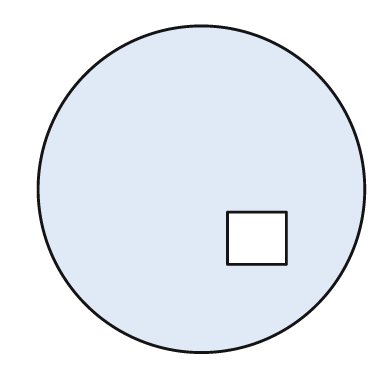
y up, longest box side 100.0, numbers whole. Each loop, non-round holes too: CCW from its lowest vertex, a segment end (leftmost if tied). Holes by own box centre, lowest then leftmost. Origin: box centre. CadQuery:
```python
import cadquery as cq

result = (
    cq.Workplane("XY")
    .moveTo(0.0, 0.0)
    .circle(50.0)
    .moveTo(8.0, -23.0)
    .lineTo(26.0, -23.0)
    .lineTo(26.0, -7.0)
    .lineTo(8.0, -7.0)
    .close()
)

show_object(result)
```